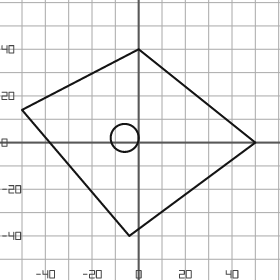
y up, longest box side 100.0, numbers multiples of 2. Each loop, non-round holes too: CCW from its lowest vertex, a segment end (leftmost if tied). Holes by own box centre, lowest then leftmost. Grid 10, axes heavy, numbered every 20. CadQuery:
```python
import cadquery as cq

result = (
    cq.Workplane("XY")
    .moveTo(-4.0, -40.0)
    .lineTo(50.0, 0.0)
    .lineTo(0.0, 40.0)
    .lineTo(-50.0, 14.0)
    .close()
    .moveTo(-6.0, 2.0)
    .circle(6.0)
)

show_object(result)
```